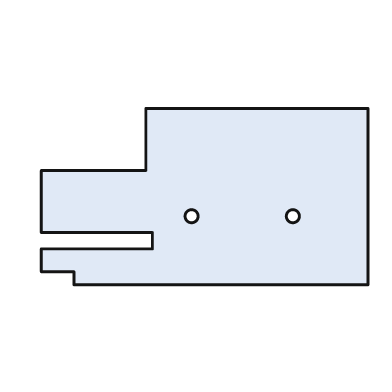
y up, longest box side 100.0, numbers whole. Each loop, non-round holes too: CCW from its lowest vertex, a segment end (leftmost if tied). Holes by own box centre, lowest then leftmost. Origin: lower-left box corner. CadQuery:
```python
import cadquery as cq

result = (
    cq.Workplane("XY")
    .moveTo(10.0, 0.0)
    .lineTo(100.0, 0.0)
    .lineTo(100.0, 54.0)
    .lineTo(32.0, 54.0)
    .lineTo(32.0, 35.0)
    .lineTo(0.0, 35.0)
    .lineTo(0.0, 16.0)
    .lineTo(34.0, 16.0)
    .lineTo(34.0, 11.0)
    .lineTo(0.0, 11.0)
    .lineTo(0.0, 4.0)
    .lineTo(10.0, 4.0)
    .close()
    .moveTo(46.0, 21.0)
    .circle(2.0)
    .moveTo(77.0, 21.0)
    .circle(2.0)
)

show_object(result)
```